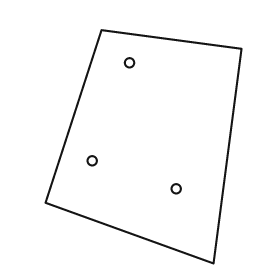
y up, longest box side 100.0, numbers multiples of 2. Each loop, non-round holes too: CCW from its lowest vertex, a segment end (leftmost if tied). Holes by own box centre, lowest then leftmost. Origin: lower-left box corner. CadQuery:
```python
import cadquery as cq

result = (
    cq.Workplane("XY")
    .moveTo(72.0, 0.0)
    .lineTo(84.0, 92.0)
    .lineTo(24.0, 100.0)
    .lineTo(0.0, 26.0)
    .close()
    .moveTo(56.0, 32.0)
    .circle(2.0)
    .moveTo(20.0, 44.0)
    .circle(2.0)
    .moveTo(36.0, 86.0)
    .circle(2.0)
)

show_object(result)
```